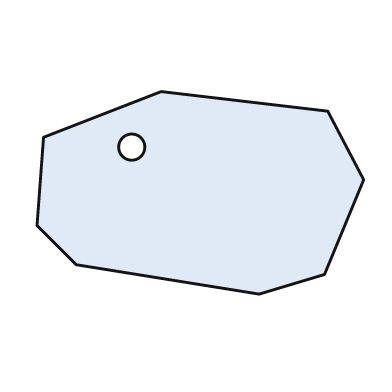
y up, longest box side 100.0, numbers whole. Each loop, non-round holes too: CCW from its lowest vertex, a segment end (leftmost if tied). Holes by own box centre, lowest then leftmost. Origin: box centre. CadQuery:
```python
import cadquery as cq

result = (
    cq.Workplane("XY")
    .moveTo(18.0, -31.0)
    .lineTo(38.0, -25.0)
    .lineTo(50.0, 4.0)
    .lineTo(39.0, 25.0)
    .lineTo(-12.0, 31.0)
    .lineTo(-48.0, 17.0)
    .lineTo(-50.0, -10.0)
    .lineTo(-38.0, -22.0)
    .close()
    .moveTo(-21.0, 14.0)
    .circle(4.0)
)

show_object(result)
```